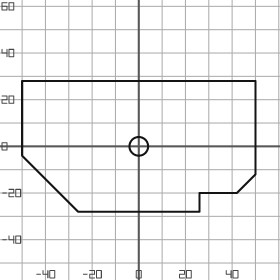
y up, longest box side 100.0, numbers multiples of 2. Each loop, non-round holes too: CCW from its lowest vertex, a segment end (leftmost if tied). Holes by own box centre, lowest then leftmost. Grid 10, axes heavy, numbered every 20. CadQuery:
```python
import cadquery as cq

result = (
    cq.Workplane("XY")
    .moveTo(-26.0, -28.0)
    .lineTo(26.0, -28.0)
    .lineTo(26.0, -20.0)
    .lineTo(42.0, -20.0)
    .lineTo(50.0, -12.0)
    .lineTo(50.0, 28.0)
    .lineTo(-50.0, 28.0)
    .lineTo(-50.0, -4.0)
    .close()
    .moveTo(0.0, 0.0)
    .circle(4.0)
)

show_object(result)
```